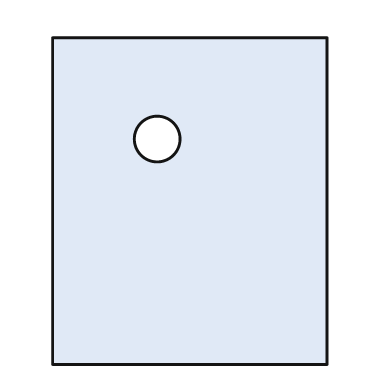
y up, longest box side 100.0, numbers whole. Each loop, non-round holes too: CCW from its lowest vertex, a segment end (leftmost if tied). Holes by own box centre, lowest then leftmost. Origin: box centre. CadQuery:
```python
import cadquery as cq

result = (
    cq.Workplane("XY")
    .moveTo(-42.0, -50.0)
    .lineTo(42.0, -50.0)
    .lineTo(42.0, 50.0)
    .lineTo(-42.0, 50.0)
    .close()
    .moveTo(-10.0, 19.0)
    .circle(7.0)
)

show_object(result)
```